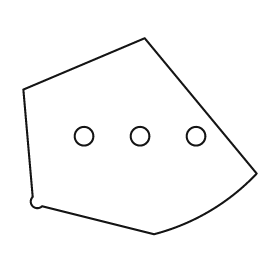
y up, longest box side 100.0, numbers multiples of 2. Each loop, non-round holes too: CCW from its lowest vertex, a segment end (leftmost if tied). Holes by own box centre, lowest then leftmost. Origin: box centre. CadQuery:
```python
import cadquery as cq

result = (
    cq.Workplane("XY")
    .moveTo(6.0, -42.0)
    .threePointArc((30.0, -32.0), (50.0, -16.0))
    .lineTo(2.0, 42.0)
    .lineTo(-50.0, 20.0)
    .lineTo(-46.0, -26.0)
    .threePointArc((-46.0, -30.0), (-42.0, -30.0))
    .close()
    .moveTo(-24.0, 0.0)
    .circle(4.0)
    .moveTo(0.0, 0.0)
    .circle(4.0)
    .moveTo(24.0, 0.0)
    .circle(4.0)
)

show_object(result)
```